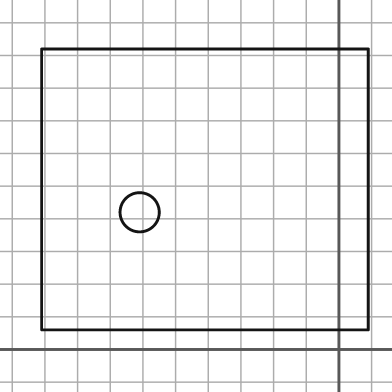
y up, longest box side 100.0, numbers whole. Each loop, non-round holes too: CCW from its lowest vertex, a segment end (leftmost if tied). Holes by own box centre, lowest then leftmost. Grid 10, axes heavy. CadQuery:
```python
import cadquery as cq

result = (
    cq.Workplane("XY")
    .moveTo(-91.0, 6.0)
    .lineTo(9.0, 6.0)
    .lineTo(9.0, 92.0)
    .lineTo(-91.0, 92.0)
    .close()
    .moveTo(-61.0, 42.0)
    .circle(6.0)
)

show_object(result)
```